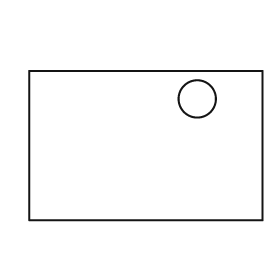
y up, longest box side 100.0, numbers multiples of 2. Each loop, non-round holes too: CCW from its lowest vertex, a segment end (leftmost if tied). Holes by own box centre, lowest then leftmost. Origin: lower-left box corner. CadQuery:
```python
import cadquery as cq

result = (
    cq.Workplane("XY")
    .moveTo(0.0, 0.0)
    .lineTo(100.0, 0.0)
    .lineTo(100.0, 64.0)
    .lineTo(0.0, 64.0)
    .close()
    .moveTo(72.0, 52.0)
    .circle(8.0)
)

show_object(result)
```